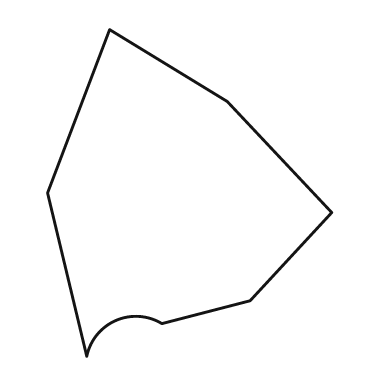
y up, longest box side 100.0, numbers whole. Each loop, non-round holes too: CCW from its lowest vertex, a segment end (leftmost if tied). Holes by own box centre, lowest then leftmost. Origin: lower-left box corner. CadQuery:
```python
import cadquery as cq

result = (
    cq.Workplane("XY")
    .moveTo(12.0, 0.0)
    .threePointArc((21.0, 11.0), (35.0, 10.0))
    .lineTo(62.0, 17.0)
    .lineTo(87.0, 44.0)
    .lineTo(55.0, 78.0)
    .lineTo(19.0, 100.0)
    .lineTo(0.0, 50.0)
    .close()
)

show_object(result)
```